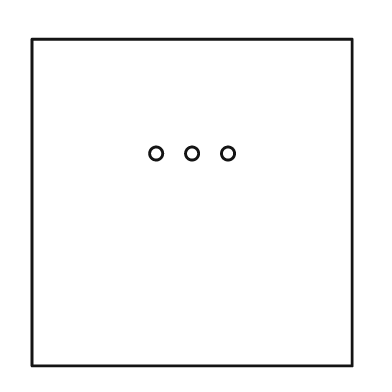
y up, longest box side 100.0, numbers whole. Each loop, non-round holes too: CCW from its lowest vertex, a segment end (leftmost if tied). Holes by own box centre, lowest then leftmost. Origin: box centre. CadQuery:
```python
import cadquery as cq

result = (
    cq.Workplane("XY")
    .moveTo(-49.0, -50.0)
    .lineTo(49.0, -50.0)
    .lineTo(49.0, 50.0)
    .lineTo(-49.0, 50.0)
    .close()
    .moveTo(-11.0, 15.0)
    .circle(2.0)
    .moveTo(0.0, 15.0)
    .circle(2.0)
    .moveTo(11.0, 15.0)
    .circle(2.0)
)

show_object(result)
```